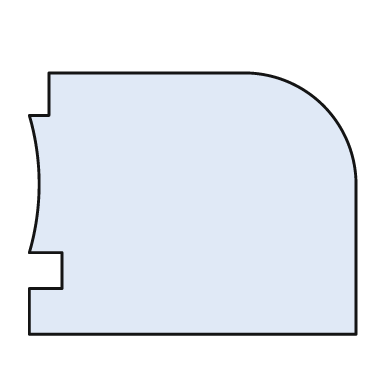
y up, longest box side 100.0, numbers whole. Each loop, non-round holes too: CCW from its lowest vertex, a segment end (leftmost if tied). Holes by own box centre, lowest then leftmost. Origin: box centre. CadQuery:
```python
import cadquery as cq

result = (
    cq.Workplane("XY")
    .moveTo(-50.0, -40.0)
    .lineTo(50.0, -40.0)
    .lineTo(50.0, 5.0)
    .threePointArc((40.0, 30.0), (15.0, 40.0))
    .lineTo(-44.0, 40.0)
    .lineTo(-44.0, 27.0)
    .lineTo(-50.0, 27.0)
    .threePointArc((-47.0, 6.0), (-50.0, -15.0))
    .lineTo(-40.0, -15.0)
    .lineTo(-40.0, -26.0)
    .lineTo(-50.0, -26.0)
    .close()
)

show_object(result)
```